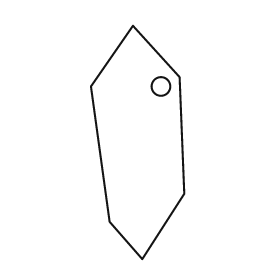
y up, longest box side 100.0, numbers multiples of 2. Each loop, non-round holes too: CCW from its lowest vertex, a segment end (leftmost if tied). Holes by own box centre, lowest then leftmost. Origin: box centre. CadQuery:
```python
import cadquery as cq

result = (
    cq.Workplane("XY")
    .moveTo(2.0, -50.0)
    .lineTo(20.0, -22.0)
    .lineTo(18.0, 28.0)
    .lineTo(-2.0, 50.0)
    .lineTo(-20.0, 24.0)
    .lineTo(-12.0, -34.0)
    .close()
    .moveTo(10.0, 24.0)
    .circle(4.0)
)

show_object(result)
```